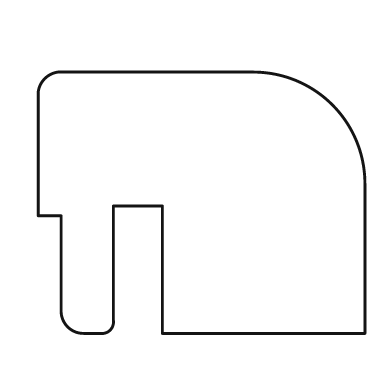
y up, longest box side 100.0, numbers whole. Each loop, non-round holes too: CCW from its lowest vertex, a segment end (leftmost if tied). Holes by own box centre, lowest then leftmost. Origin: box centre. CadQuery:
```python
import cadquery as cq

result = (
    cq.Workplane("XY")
    .moveTo(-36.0, -40.0)
    .lineTo(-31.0, -40.0)
    .threePointArc((-28.0, -39.0), (-27.0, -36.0))
    .lineTo(-27.0, -1.0)
    .lineTo(-12.0, -1.0)
    .lineTo(-12.0, -40.0)
    .lineTo(50.0, -40.0)
    .lineTo(50.0, 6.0)
    .threePointArc((40.0, 30.0), (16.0, 40.0))
    .lineTo(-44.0, 40.0)
    .threePointArc((-48.0, 38.0), (-50.0, 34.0))
    .lineTo(-50.0, -4.0)
    .lineTo(-43.0, -4.0)
    .lineTo(-43.0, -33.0)
    .threePointArc((-41.0, -38.0), (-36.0, -40.0))
    .close()
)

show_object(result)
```